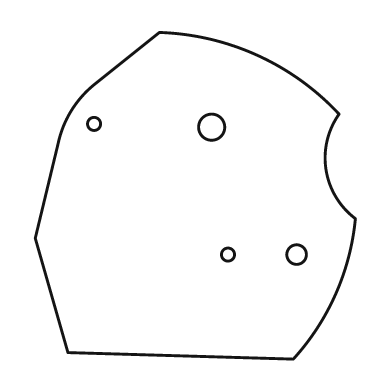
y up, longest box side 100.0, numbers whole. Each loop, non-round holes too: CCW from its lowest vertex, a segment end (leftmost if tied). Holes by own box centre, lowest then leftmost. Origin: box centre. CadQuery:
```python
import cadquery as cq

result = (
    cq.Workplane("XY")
    .moveTo(30.0, -50.0)
    .threePointArc((43.0, -30.0), (49.0, -7.0))
    .threePointArc((40.0, 8.0), (44.0, 25.0))
    .threePointArc((19.0, 43.0), (-11.0, 50.0))
    .lineTo(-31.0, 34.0)
    .threePointArc((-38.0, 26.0), (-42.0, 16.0))
    .lineTo(-49.0, -13.0)
    .lineTo(-39.0, -48.0)
    .close()
    .moveTo(10.0, -18.0)
    .circle(2.0)
    .moveTo(31.0, -18.0)
    .circle(3.0)
    .moveTo(5.0, 21.0)
    .circle(4.0)
    .moveTo(-31.0, 22.0)
    .circle(2.0)
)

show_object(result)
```